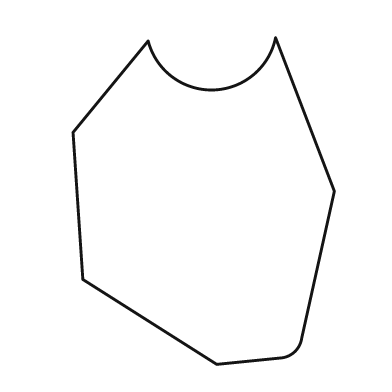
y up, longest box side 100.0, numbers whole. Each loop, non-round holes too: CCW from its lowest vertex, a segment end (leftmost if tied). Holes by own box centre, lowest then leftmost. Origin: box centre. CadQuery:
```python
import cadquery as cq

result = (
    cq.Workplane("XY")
    .moveTo(4.0, -50.0)
    .lineTo(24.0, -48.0)
    .threePointArc((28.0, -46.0), (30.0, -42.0))
    .lineTo(40.0, 3.0)
    .lineTo(22.0, 50.0)
    .threePointArc((3.0, 34.0), (-17.0, 49.0))
    .lineTo(-40.0, 21.0)
    .lineTo(-37.0, -24.0)
    .close()
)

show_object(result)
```